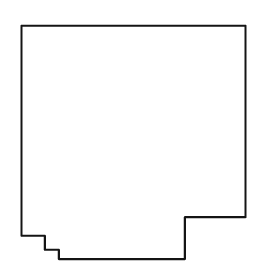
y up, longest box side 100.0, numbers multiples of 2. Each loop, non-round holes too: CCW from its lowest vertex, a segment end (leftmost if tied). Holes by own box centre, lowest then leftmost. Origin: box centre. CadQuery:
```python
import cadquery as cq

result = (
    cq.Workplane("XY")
    .moveTo(-32.0, -50.0)
    .lineTo(22.0, -50.0)
    .lineTo(22.0, -32.0)
    .lineTo(48.0, -32.0)
    .lineTo(48.0, 50.0)
    .lineTo(-48.0, 50.0)
    .lineTo(-48.0, -40.0)
    .lineTo(-38.0, -40.0)
    .lineTo(-38.0, -46.0)
    .lineTo(-32.0, -46.0)
    .close()
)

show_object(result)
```